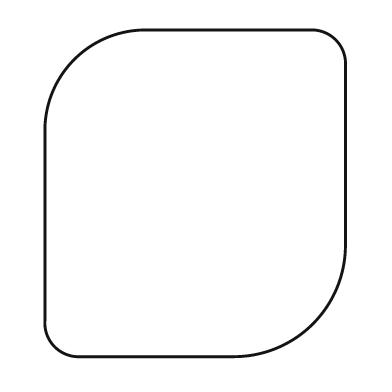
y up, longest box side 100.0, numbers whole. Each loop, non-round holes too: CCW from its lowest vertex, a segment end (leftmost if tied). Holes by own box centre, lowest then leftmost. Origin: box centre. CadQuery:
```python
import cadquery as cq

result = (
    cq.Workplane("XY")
    .moveTo(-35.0, -50.0)
    .lineTo(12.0, -50.0)
    .threePointArc((36.0, -40.0), (46.0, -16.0))
    .lineTo(46.0, 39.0)
    .threePointArc((43.0, 47.0), (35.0, 50.0))
    .lineTo(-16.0, 50.0)
    .threePointArc((-37.0, 41.0), (-46.0, 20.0))
    .lineTo(-46.0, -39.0)
    .threePointArc((-43.0, -47.0), (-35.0, -50.0))
    .close()
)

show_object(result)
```